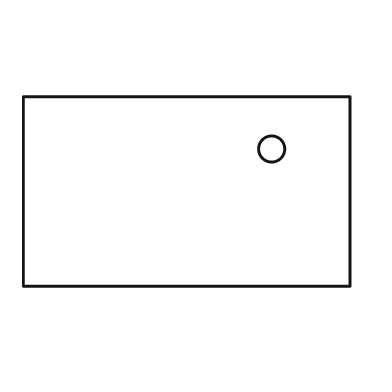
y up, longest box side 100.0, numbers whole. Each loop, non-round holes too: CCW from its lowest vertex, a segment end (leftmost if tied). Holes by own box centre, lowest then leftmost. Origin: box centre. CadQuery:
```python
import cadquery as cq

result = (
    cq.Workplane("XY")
    .moveTo(-50.0, -29.0)
    .lineTo(50.0, -29.0)
    .lineTo(50.0, 29.0)
    .lineTo(-50.0, 29.0)
    .close()
    .moveTo(26.0, 13.0)
    .circle(4.0)
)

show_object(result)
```